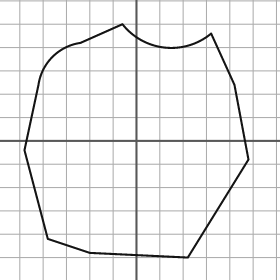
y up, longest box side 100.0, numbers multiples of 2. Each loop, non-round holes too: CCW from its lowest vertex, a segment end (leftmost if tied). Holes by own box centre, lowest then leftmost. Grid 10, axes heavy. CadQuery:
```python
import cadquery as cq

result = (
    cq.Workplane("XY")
    .moveTo(22.0, -50.0)
    .lineTo(48.0, -8.0)
    .lineTo(42.0, 24.0)
    .lineTo(32.0, 46.0)
    .threePointArc((12.0, 40.0), (-6.0, 50.0))
    .lineTo(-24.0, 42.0)
    .threePointArc((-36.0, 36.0), (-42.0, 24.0))
    .lineTo(-48.0, -4.0)
    .lineTo(-38.0, -42.0)
    .lineTo(-20.0, -48.0)
    .close()
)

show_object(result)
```